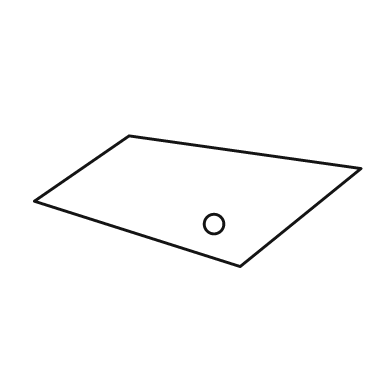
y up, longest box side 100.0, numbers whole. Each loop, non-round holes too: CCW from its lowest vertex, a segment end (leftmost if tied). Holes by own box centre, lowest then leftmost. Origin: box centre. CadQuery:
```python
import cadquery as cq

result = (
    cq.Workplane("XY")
    .moveTo(13.0, -20.0)
    .lineTo(50.0, 10.0)
    .lineTo(-21.0, 20.0)
    .lineTo(-50.0, 0.0)
    .close()
    .moveTo(5.0, -7.0)
    .circle(3.0)
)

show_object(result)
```